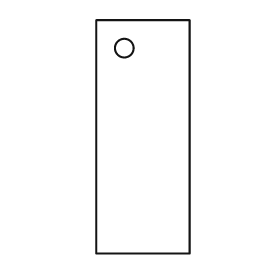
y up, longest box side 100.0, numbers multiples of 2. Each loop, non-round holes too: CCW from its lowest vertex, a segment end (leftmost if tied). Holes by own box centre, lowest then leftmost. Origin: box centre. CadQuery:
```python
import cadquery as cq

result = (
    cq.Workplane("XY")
    .moveTo(-20.0, -50.0)
    .lineTo(20.0, -50.0)
    .lineTo(20.0, 50.0)
    .lineTo(-20.0, 50.0)
    .close()
    .moveTo(-8.0, 38.0)
    .circle(4.0)
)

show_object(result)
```